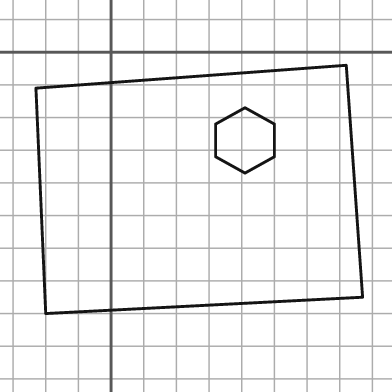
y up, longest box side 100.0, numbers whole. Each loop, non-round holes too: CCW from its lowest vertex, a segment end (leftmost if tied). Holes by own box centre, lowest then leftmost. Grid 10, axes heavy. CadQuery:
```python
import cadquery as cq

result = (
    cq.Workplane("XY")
    .moveTo(-20.0, -80.0)
    .lineTo(77.0, -75.0)
    .lineTo(72.0, -4.0)
    .lineTo(-23.0, -11.0)
    .close()
    .moveTo(41.0, -37.0)
    .lineTo(50.0, -32.0)
    .lineTo(50.0, -22.0)
    .lineTo(41.0, -17.0)
    .lineTo(32.0, -22.0)
    .lineTo(32.0, -32.0)
    .close()
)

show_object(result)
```